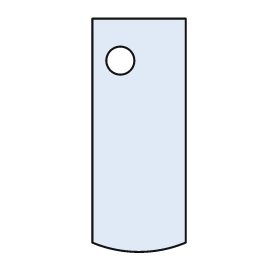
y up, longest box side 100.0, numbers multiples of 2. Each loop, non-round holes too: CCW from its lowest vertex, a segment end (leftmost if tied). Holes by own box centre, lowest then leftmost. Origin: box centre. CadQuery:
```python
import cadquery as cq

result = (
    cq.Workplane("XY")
    .moveTo(-20.0, -46.0)
    .threePointArc((0.0, -50.0), (20.0, -46.0))
    .lineTo(20.0, 50.0)
    .lineTo(-20.0, 50.0)
    .close()
    .moveTo(-8.0, 32.0)
    .circle(6.0)
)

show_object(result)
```